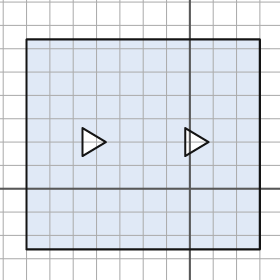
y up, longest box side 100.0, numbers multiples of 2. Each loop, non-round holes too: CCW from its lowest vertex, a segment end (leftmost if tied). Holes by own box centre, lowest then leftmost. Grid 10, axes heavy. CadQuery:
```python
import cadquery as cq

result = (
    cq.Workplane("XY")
    .moveTo(-70.0, -26.0)
    .lineTo(30.0, -26.0)
    .lineTo(30.0, 64.0)
    .lineTo(-70.0, 64.0)
    .close()
    .moveTo(-46.0, 14.0)
    .lineTo(-36.0, 20.0)
    .lineTo(-46.0, 26.0)
    .close()
    .moveTo(-2.0, 14.0)
    .lineTo(8.0, 20.0)
    .lineTo(-2.0, 26.0)
    .close()
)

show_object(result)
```